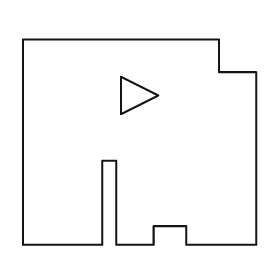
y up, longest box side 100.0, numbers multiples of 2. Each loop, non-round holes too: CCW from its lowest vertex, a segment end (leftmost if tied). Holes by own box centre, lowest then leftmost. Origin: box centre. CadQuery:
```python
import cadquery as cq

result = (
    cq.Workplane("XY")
    .moveTo(-50.0, -44.0)
    .lineTo(-16.0, -44.0)
    .lineTo(-16.0, -8.0)
    .lineTo(-10.0, -8.0)
    .lineTo(-10.0, -44.0)
    .lineTo(6.0, -44.0)
    .lineTo(6.0, -36.0)
    .lineTo(20.0, -36.0)
    .lineTo(20.0, -44.0)
    .lineTo(50.0, -44.0)
    .lineTo(50.0, 30.0)
    .lineTo(34.0, 30.0)
    .lineTo(34.0, 44.0)
    .lineTo(-50.0, 44.0)
    .close()
    .moveTo(-8.0, 12.0)
    .lineTo(8.0, 20.0)
    .lineTo(-8.0, 28.0)
    .close()
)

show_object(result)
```